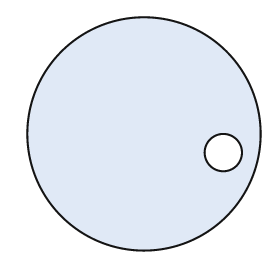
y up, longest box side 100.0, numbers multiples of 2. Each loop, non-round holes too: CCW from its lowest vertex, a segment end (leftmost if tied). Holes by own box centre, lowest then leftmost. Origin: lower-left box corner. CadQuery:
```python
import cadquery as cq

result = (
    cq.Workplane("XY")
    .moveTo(50.0, 50.0)
    .circle(50.0)
    .moveTo(84.0, 42.0)
    .circle(8.0)
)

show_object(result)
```